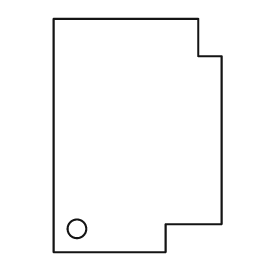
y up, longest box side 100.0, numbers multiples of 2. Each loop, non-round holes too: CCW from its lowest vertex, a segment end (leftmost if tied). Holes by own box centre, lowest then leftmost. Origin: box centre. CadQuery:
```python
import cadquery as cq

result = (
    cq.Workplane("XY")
    .moveTo(-36.0, -50.0)
    .lineTo(12.0, -50.0)
    .lineTo(12.0, -38.0)
    .lineTo(36.0, -38.0)
    .lineTo(36.0, 34.0)
    .lineTo(26.0, 34.0)
    .lineTo(26.0, 50.0)
    .lineTo(-36.0, 50.0)
    .close()
    .moveTo(-26.0, -40.0)
    .circle(4.0)
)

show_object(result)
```